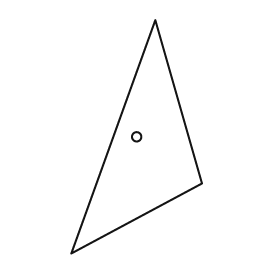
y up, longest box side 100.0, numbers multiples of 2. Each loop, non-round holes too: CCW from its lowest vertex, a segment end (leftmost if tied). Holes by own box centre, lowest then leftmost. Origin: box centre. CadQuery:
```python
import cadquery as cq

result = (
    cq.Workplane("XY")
    .moveTo(-28.0, -50.0)
    .lineTo(28.0, -20.0)
    .lineTo(8.0, 50.0)
    .close()
    .moveTo(0.0, 0.0)
    .circle(2.0)
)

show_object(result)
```